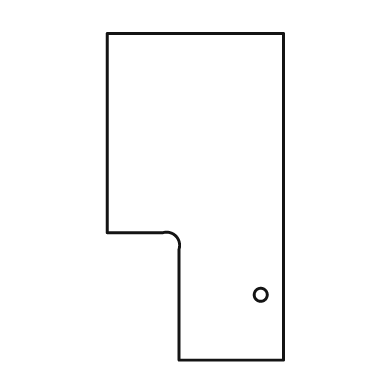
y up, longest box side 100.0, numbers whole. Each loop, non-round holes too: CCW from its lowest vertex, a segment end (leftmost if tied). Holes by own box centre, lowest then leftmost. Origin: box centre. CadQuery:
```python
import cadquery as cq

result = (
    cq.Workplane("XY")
    .moveTo(-5.0, -50.0)
    .lineTo(27.0, -50.0)
    .lineTo(27.0, 50.0)
    .lineTo(-27.0, 50.0)
    .lineTo(-27.0, -11.0)
    .lineTo(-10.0, -11.0)
    .threePointArc((-6.0, -12.0), (-5.0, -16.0))
    .close()
    .moveTo(20.0, -30.0)
    .circle(2.0)
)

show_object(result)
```